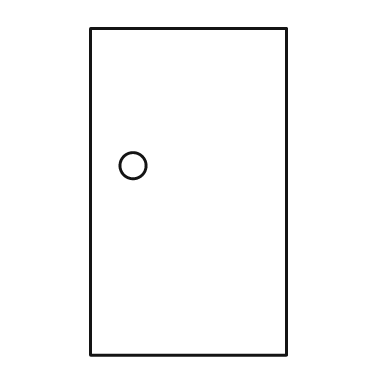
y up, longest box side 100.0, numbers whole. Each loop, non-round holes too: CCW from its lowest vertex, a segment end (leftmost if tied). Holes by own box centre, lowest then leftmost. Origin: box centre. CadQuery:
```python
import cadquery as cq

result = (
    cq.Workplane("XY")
    .moveTo(-30.0, -50.0)
    .lineTo(30.0, -50.0)
    .lineTo(30.0, 50.0)
    .lineTo(-30.0, 50.0)
    .close()
    .moveTo(-17.0, 8.0)
    .circle(4.0)
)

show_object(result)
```